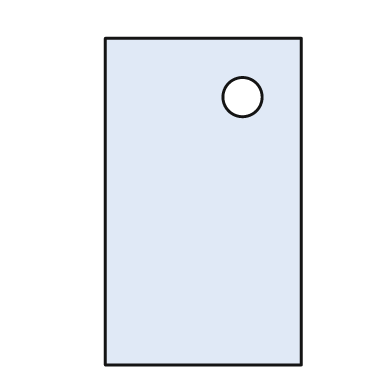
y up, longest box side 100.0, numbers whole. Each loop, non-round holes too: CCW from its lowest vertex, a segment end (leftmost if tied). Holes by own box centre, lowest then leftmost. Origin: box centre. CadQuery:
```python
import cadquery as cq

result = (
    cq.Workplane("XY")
    .moveTo(-30.0, -50.0)
    .lineTo(30.0, -50.0)
    .lineTo(30.0, 50.0)
    .lineTo(-30.0, 50.0)
    .close()
    .moveTo(12.0, 32.0)
    .circle(6.0)
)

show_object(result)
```